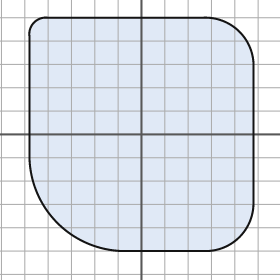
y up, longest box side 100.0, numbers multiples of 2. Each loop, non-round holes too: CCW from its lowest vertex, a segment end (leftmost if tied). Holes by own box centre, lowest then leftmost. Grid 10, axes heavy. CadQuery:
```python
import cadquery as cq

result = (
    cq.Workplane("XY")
    .moveTo(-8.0, -50.0)
    .lineTo(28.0, -50.0)
    .threePointArc((42.0, -44.0), (48.0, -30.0))
    .lineTo(48.0, 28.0)
    .threePointArc((42.0, 44.0), (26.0, 50.0))
    .lineTo(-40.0, 50.0)
    .threePointArc((-46.0, 48.0), (-48.0, 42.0))
    .lineTo(-48.0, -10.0)
    .threePointArc((-36.0, -38.0), (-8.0, -50.0))
    .close()
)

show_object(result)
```